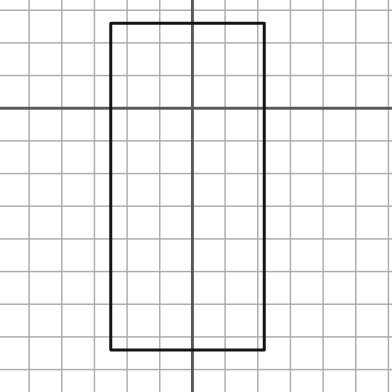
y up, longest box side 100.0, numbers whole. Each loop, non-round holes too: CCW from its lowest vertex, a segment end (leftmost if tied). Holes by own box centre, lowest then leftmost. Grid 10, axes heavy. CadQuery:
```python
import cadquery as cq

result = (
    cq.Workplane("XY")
    .moveTo(-25.0, -74.0)
    .lineTo(22.0, -74.0)
    .lineTo(22.0, 26.0)
    .lineTo(-25.0, 26.0)
    .close()
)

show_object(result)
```